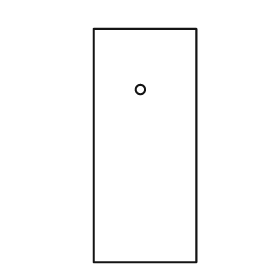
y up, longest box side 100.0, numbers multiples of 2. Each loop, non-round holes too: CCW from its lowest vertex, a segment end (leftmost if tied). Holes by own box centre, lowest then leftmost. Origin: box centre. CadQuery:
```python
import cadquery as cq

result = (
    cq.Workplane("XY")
    .moveTo(-22.0, -50.0)
    .lineTo(22.0, -50.0)
    .lineTo(22.0, 50.0)
    .lineTo(-22.0, 50.0)
    .close()
    .moveTo(-2.0, 24.0)
    .circle(2.0)
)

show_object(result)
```